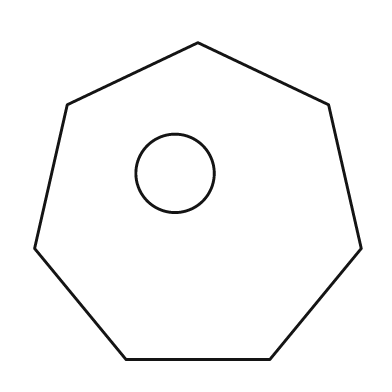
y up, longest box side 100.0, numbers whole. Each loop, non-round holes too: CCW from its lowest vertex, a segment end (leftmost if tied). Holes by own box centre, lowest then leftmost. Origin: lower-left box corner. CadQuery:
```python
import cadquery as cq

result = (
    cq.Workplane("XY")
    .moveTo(28.0, 0.0)
    .lineTo(72.0, 0.0)
    .lineTo(100.0, 34.0)
    .lineTo(90.0, 78.0)
    .lineTo(50.0, 97.0)
    .lineTo(10.0, 78.0)
    .lineTo(0.0, 34.0)
    .close()
    .moveTo(43.0, 57.0)
    .circle(12.0)
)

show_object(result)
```